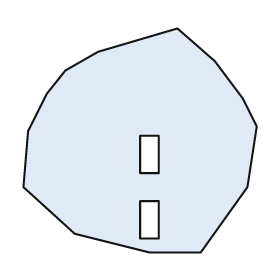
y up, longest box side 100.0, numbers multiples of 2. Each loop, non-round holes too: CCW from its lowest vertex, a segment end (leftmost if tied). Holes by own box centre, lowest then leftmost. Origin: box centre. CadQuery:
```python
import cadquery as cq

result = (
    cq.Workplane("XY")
    .moveTo(4.0, -48.0)
    .lineTo(26.0, -48.0)
    .lineTo(46.0, -20.0)
    .lineTo(50.0, 6.0)
    .lineTo(44.0, 18.0)
    .lineTo(32.0, 34.0)
    .lineTo(16.0, 48.0)
    .lineTo(-18.0, 38.0)
    .lineTo(-32.0, 30.0)
    .lineTo(-40.0, 20.0)
    .lineTo(-48.0, 4.0)
    .lineTo(-50.0, -20.0)
    .lineTo(-28.0, -40.0)
    .close()
    .moveTo(0.0, -42.0)
    .lineTo(8.0, -42.0)
    .lineTo(8.0, -26.0)
    .lineTo(0.0, -26.0)
    .close()
    .moveTo(0.0, -14.0)
    .lineTo(8.0, -14.0)
    .lineTo(8.0, 2.0)
    .lineTo(0.0, 2.0)
    .close()
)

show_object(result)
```